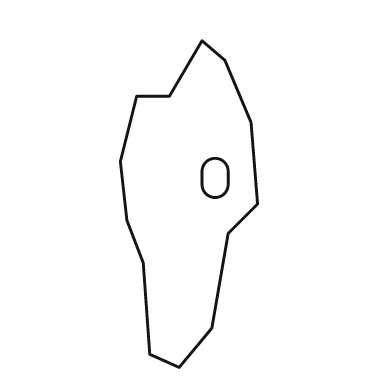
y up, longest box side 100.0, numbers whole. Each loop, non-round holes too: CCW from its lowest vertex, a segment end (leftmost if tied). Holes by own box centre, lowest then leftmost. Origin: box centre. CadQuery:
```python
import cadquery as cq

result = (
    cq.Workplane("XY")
    .moveTo(-3.0, -50.0)
    .lineTo(7.0, -38.0)
    .lineTo(12.0, -9.0)
    .lineTo(21.0, 0.0)
    .lineTo(19.0, 25.0)
    .lineTo(11.0, 44.0)
    .lineTo(4.0, 50.0)
    .lineTo(-6.0, 33.0)
    .lineTo(-16.0, 33.0)
    .lineTo(-21.0, 13.0)
    .lineTo(-19.0, -5.0)
    .lineTo(-14.0, -18.0)
    .lineTo(-12.0, -46.0)
    .close()
    .moveTo(4.0, 6.0)
    .threePointArc((8.0, 2.0), (12.0, 6.0))
    .lineTo(12.0, 10.0)
    .threePointArc((8.0, 14.0), (4.0, 10.0))
    .close()
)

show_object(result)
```